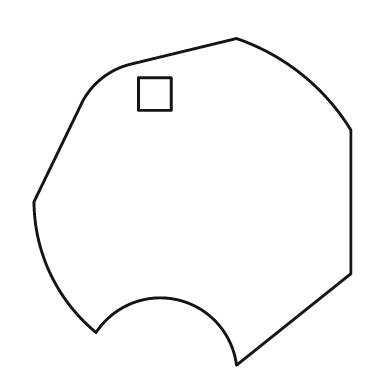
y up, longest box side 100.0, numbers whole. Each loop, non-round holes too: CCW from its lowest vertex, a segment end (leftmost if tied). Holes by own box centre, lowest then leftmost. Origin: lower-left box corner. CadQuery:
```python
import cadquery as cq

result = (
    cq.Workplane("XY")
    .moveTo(62.0, 0.0)
    .lineTo(97.0, 28.0)
    .lineTo(97.0, 72.0)
    .threePointArc((82.0, 89.0), (62.0, 100.0))
    .lineTo(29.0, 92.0)
    .threePointArc((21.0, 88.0), (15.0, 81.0))
    .lineTo(0.0, 50.0)
    .threePointArc((5.0, 28.0), (19.0, 10.0))
    .threePointArc((44.0, 20.0), (62.0, 0.0))
    .close()
    .moveTo(32.0, 78.0)
    .lineTo(42.0, 78.0)
    .lineTo(42.0, 88.0)
    .lineTo(32.0, 88.0)
    .close()
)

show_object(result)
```